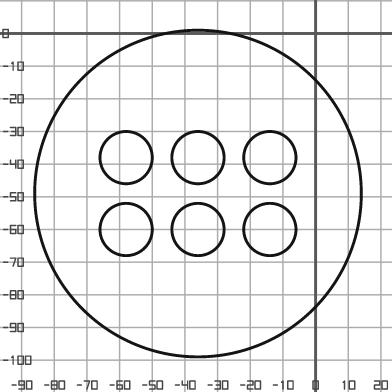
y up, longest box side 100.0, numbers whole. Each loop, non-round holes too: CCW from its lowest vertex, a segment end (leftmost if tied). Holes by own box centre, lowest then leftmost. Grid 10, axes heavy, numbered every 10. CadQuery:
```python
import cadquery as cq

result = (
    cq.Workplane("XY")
    .moveTo(-36.0, -49.0)
    .circle(50.0)
    .moveTo(-58.0, -60.0)
    .circle(8.0)
    .moveTo(-36.0, -60.0)
    .circle(8.0)
    .moveTo(-14.0, -60.0)
    .circle(8.0)
    .moveTo(-58.0, -38.0)
    .circle(8.0)
    .moveTo(-36.0, -38.0)
    .circle(8.0)
    .moveTo(-14.0, -38.0)
    .circle(8.0)
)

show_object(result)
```